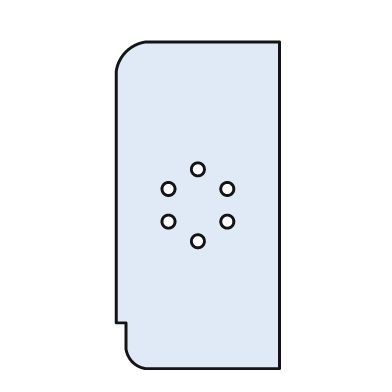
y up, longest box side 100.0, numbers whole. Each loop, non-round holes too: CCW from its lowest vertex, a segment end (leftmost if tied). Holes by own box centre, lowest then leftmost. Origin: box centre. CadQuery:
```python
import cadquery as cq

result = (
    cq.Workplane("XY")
    .moveTo(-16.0, -50.0)
    .lineTo(25.0, -50.0)
    .lineTo(25.0, 50.0)
    .lineTo(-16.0, 50.0)
    .threePointArc((-22.0, 47.0), (-25.0, 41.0))
    .lineTo(-25.0, -36.0)
    .lineTo(-22.0, -36.0)
    .lineTo(-22.0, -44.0)
    .threePointArc((-20.0, -48.0), (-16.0, -50.0))
    .close()
    .moveTo(0.0, -11.0)
    .circle(2.0)
    .moveTo(-9.0, -5.0)
    .circle(2.0)
    .moveTo(9.0, -5.0)
    .circle(2.0)
    .moveTo(-9.0, 5.0)
    .circle(2.0)
    .moveTo(9.0, 5.0)
    .circle(2.0)
    .moveTo(0.0, 11.0)
    .circle(2.0)
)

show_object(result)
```